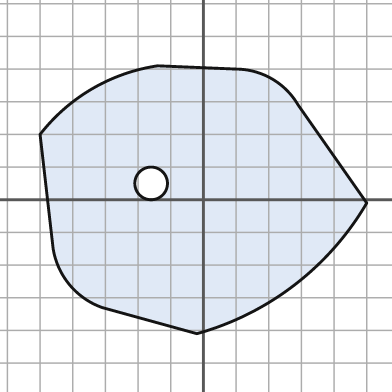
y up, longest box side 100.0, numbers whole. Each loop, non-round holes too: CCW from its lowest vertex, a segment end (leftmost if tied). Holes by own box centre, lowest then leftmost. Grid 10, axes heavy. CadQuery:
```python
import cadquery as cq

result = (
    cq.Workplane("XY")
    .moveTo(-2.0, -41.0)
    .threePointArc((28.0, -26.0), (50.0, -1.0))
    .lineTo(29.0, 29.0)
    .threePointArc((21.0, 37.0), (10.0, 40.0))
    .lineTo(-14.0, 41.0)
    .threePointArc((-34.0, 34.0), (-50.0, 20.0))
    .lineTo(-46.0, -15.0)
    .threePointArc((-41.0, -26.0), (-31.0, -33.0))
    .close()
    .moveTo(-16.0, 5.0)
    .circle(5.0)
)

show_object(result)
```